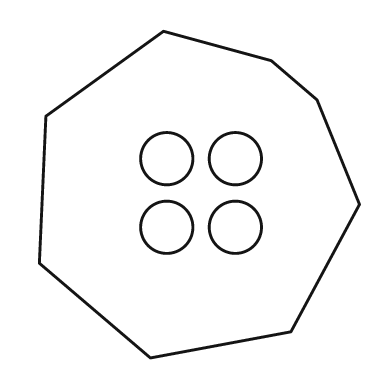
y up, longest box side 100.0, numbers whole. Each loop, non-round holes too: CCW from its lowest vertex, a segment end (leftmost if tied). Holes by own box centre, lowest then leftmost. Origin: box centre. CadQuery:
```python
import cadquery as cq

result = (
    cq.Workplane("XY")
    .moveTo(-15.0, -50.0)
    .lineTo(28.0, -42.0)
    .lineTo(49.0, -3.0)
    .lineTo(36.0, 29.0)
    .lineTo(22.0, 41.0)
    .lineTo(-11.0, 50.0)
    .lineTo(-47.0, 24.0)
    .lineTo(-49.0, -21.0)
    .close()
    .moveTo(-10.0, -10.0)
    .circle(8.0)
    .moveTo(11.0, -10.0)
    .circle(8.0)
    .moveTo(-10.0, 11.0)
    .circle(8.0)
    .moveTo(11.0, 11.0)
    .circle(8.0)
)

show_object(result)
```